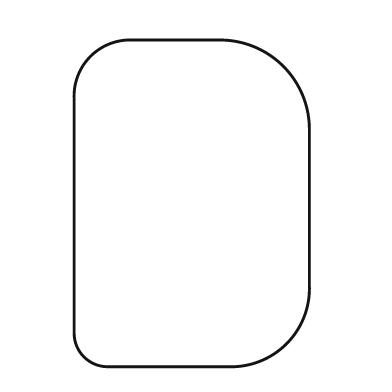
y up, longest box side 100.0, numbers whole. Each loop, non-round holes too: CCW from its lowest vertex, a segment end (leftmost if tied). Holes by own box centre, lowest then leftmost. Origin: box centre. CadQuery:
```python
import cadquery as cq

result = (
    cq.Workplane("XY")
    .moveTo(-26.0, -50.0)
    .lineTo(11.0, -50.0)
    .threePointArc((29.0, -43.0), (36.0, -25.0))
    .lineTo(36.0, 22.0)
    .threePointArc((28.0, 42.0), (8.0, 50.0))
    .lineTo(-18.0, 50.0)
    .threePointArc((-31.0, 45.0), (-36.0, 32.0))
    .lineTo(-36.0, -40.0)
    .threePointArc((-33.0, -47.0), (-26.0, -50.0))
    .close()
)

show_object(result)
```